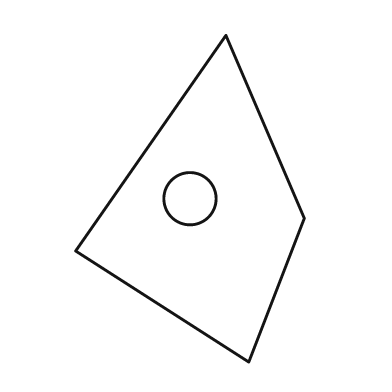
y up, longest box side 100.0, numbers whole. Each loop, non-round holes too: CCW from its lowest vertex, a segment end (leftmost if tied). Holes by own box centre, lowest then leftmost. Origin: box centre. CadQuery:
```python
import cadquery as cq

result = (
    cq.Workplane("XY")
    .moveTo(18.0, -50.0)
    .lineTo(35.0, -6.0)
    .lineTo(11.0, 50.0)
    .lineTo(-35.0, -16.0)
    .close()
    .moveTo(0.0, 0.0)
    .circle(8.0)
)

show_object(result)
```